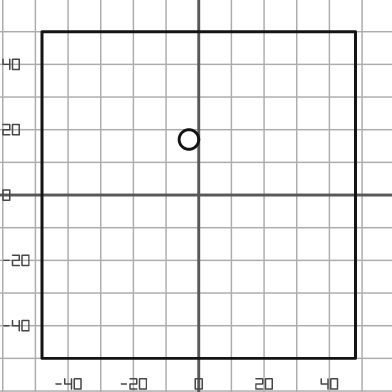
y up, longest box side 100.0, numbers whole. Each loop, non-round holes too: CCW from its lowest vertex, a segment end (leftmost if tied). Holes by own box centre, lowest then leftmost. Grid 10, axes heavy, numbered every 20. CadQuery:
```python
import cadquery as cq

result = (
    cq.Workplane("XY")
    .moveTo(-48.0, -50.0)
    .lineTo(48.0, -50.0)
    .lineTo(48.0, 50.0)
    .lineTo(-48.0, 50.0)
    .close()
    .moveTo(-3.0, 17.0)
    .circle(3.0)
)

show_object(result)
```